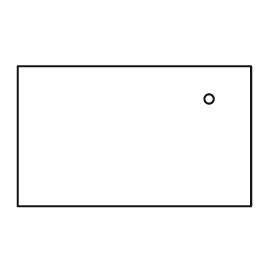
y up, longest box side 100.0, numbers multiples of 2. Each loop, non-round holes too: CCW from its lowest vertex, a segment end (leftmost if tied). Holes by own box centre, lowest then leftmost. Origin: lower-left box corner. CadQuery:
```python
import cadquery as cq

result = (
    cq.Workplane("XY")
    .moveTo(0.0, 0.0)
    .lineTo(100.0, 0.0)
    .lineTo(100.0, 60.0)
    .lineTo(0.0, 60.0)
    .close()
    .moveTo(82.0, 46.0)
    .circle(2.0)
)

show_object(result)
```